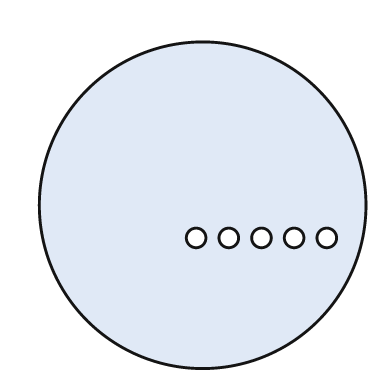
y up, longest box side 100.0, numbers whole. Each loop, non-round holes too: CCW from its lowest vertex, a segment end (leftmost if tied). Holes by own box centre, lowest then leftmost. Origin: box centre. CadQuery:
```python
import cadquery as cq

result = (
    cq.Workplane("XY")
    .moveTo(0.0, 0.0)
    .circle(50.0)
    .moveTo(-2.0, -10.0)
    .circle(3.0)
    .moveTo(8.0, -10.0)
    .circle(3.0)
    .moveTo(18.0, -10.0)
    .circle(3.0)
    .moveTo(28.0, -10.0)
    .circle(3.0)
    .moveTo(38.0, -10.0)
    .circle(3.0)
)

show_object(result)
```